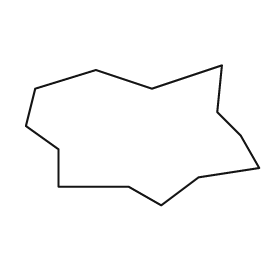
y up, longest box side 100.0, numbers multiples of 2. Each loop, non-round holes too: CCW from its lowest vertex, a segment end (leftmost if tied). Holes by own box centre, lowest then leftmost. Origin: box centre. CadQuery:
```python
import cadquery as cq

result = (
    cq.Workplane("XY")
    .moveTo(8.0, -30.0)
    .lineTo(24.0, -18.0)
    .lineTo(50.0, -14.0)
    .lineTo(42.0, 0.0)
    .lineTo(32.0, 10.0)
    .lineTo(34.0, 30.0)
    .lineTo(4.0, 20.0)
    .lineTo(-20.0, 28.0)
    .lineTo(-46.0, 20.0)
    .lineTo(-50.0, 4.0)
    .lineTo(-36.0, -6.0)
    .lineTo(-36.0, -22.0)
    .lineTo(-6.0, -22.0)
    .close()
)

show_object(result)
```